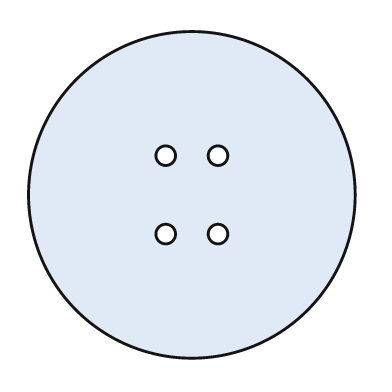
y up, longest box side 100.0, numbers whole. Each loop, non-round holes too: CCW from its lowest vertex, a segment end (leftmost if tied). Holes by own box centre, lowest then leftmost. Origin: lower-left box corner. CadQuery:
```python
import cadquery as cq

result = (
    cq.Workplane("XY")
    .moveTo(50.0, 50.0)
    .circle(50.0)
    .moveTo(42.0, 38.0)
    .circle(3.0)
    .moveTo(58.0, 38.0)
    .circle(3.0)
    .moveTo(42.0, 62.0)
    .circle(3.0)
    .moveTo(58.0, 62.0)
    .circle(3.0)
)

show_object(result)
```